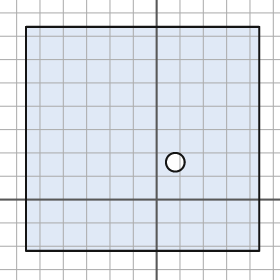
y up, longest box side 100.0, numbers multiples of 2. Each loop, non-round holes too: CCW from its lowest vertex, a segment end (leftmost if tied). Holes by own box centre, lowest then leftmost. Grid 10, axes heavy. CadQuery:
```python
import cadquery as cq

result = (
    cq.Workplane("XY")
    .moveTo(-56.0, -22.0)
    .lineTo(44.0, -22.0)
    .lineTo(44.0, 74.0)
    .lineTo(-56.0, 74.0)
    .close()
    .moveTo(8.0, 16.0)
    .circle(4.0)
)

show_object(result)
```